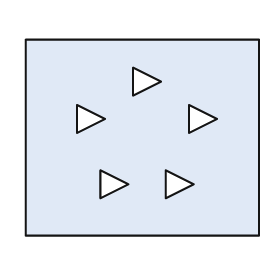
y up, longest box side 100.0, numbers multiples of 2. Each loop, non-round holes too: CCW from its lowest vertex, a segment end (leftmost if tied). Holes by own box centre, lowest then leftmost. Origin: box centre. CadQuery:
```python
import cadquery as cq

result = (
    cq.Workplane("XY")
    .moveTo(-50.0, -42.0)
    .lineTo(50.0, -42.0)
    .lineTo(50.0, 42.0)
    .lineTo(-50.0, 42.0)
    .close()
    .moveTo(-18.0, -26.0)
    .lineTo(-6.0, -20.0)
    .lineTo(-18.0, -14.0)
    .close()
    .moveTo(10.0, -26.0)
    .lineTo(22.0, -20.0)
    .lineTo(10.0, -14.0)
    .close()
    .moveTo(-28.0, 2.0)
    .lineTo(-16.0, 8.0)
    .lineTo(-28.0, 14.0)
    .close()
    .moveTo(20.0, 2.0)
    .lineTo(32.0, 8.0)
    .lineTo(20.0, 14.0)
    .close()
    .moveTo(-4.0, 18.0)
    .lineTo(8.0, 24.0)
    .lineTo(-4.0, 30.0)
    .close()
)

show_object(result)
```